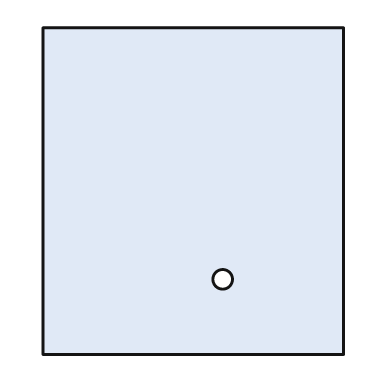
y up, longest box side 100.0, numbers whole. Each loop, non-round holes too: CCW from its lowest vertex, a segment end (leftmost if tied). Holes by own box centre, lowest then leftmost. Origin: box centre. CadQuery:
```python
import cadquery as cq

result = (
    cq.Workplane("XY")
    .moveTo(-46.0, -50.0)
    .lineTo(46.0, -50.0)
    .lineTo(46.0, 50.0)
    .lineTo(-46.0, 50.0)
    .close()
    .moveTo(9.0, -27.0)
    .circle(3.0)
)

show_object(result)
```